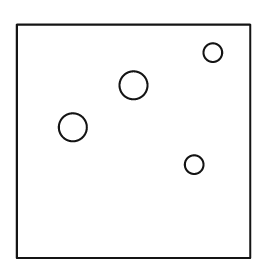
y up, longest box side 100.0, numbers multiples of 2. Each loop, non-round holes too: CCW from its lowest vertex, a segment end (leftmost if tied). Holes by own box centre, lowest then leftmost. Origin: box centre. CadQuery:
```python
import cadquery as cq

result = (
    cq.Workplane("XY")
    .moveTo(-50.0, -50.0)
    .lineTo(50.0, -50.0)
    .lineTo(50.0, 50.0)
    .lineTo(-50.0, 50.0)
    .close()
    .moveTo(26.0, -10.0)
    .circle(4.0)
    .moveTo(-26.0, 6.0)
    .circle(6.0)
    .moveTo(0.0, 24.0)
    .circle(6.0)
    .moveTo(34.0, 38.0)
    .circle(4.0)
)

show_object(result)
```